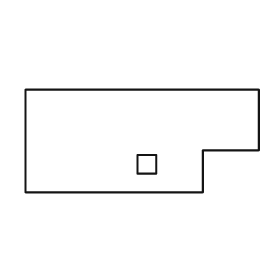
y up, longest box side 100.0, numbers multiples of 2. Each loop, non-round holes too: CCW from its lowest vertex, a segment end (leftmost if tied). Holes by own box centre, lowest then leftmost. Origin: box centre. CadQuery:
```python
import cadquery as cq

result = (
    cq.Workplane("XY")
    .moveTo(-50.0, -22.0)
    .lineTo(26.0, -22.0)
    .lineTo(26.0, -4.0)
    .lineTo(50.0, -4.0)
    .lineTo(50.0, 22.0)
    .lineTo(-50.0, 22.0)
    .close()
    .moveTo(-2.0, -14.0)
    .lineTo(6.0, -14.0)
    .lineTo(6.0, -6.0)
    .lineTo(-2.0, -6.0)
    .close()
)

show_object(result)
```